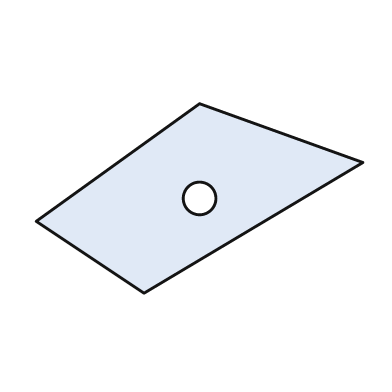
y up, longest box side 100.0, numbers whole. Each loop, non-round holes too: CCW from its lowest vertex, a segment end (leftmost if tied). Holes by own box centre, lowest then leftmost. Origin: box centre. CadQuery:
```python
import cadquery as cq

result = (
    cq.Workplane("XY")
    .moveTo(-17.0, -29.0)
    .lineTo(50.0, 11.0)
    .lineTo(0.0, 29.0)
    .lineTo(-50.0, -7.0)
    .close()
    .moveTo(0.0, 0.0)
    .circle(5.0)
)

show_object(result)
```